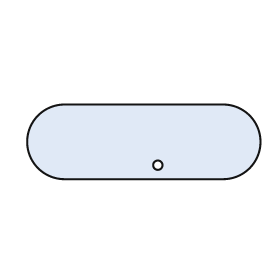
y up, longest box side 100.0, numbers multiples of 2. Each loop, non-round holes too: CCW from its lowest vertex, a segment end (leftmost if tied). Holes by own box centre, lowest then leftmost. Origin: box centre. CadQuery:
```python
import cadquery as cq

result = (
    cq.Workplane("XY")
    .moveTo(-34.0, -16.0)
    .lineTo(34.0, -16.0)
    .threePointArc((50.0, 0.0), (34.0, 16.0))
    .lineTo(-34.0, 16.0)
    .threePointArc((-50.0, 0.0), (-34.0, -16.0))
    .close()
    .moveTo(6.0, -10.0)
    .circle(2.0)
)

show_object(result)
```